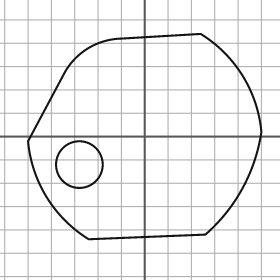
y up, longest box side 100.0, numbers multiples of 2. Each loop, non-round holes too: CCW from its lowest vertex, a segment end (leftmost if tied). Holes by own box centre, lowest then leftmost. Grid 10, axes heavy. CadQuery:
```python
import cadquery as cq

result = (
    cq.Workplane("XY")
    .moveTo(-24.0, -44.0)
    .lineTo(26.0, -42.0)
    .threePointArc((42.0, -22.0), (50.0, 2.0))
    .threePointArc((42.0, 26.0), (24.0, 44.0))
    .lineTo(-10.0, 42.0)
    .threePointArc((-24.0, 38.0), (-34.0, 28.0))
    .lineTo(-50.0, -2.0)
    .threePointArc((-42.0, -26.0), (-24.0, -44.0))
    .close()
    .moveTo(-28.0, -12.0)
    .circle(10.0)
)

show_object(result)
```